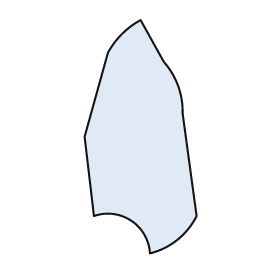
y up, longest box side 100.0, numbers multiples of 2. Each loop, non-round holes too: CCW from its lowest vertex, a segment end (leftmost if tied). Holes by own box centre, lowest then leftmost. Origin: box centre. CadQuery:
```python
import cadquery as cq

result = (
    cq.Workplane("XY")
    .moveTo(4.0, -50.0)
    .threePointArc((16.0, -44.0), (24.0, -34.0))
    .lineTo(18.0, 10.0)
    .threePointArc((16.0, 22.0), (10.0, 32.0))
    .lineTo(0.0, 50.0)
    .threePointArc((-8.0, 44.0), (-14.0, 36.0))
    .lineTo(-24.0, 0.0)
    .lineTo(-20.0, -34.0)
    .threePointArc((-4.0, -36.0), (4.0, -50.0))
    .close()
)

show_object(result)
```